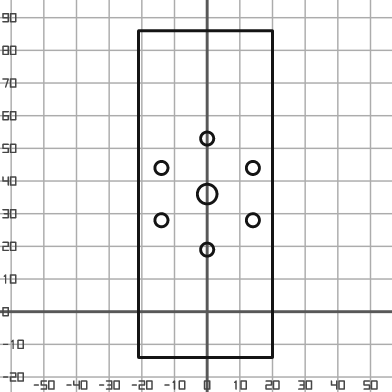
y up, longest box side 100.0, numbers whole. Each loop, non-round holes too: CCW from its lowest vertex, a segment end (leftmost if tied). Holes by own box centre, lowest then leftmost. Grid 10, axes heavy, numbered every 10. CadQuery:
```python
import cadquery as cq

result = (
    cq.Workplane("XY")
    .moveTo(-21.0, -14.0)
    .lineTo(20.0, -14.0)
    .lineTo(20.0, 86.0)
    .lineTo(-21.0, 86.0)
    .close()
    .moveTo(0.0, 19.0)
    .circle(2.0)
    .moveTo(-14.0, 28.0)
    .circle(2.0)
    .moveTo(14.0, 28.0)
    .circle(2.0)
    .moveTo(0.0, 36.0)
    .circle(3.0)
    .moveTo(-14.0, 44.0)
    .circle(2.0)
    .moveTo(14.0, 44.0)
    .circle(2.0)
    .moveTo(0.0, 53.0)
    .circle(2.0)
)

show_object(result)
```